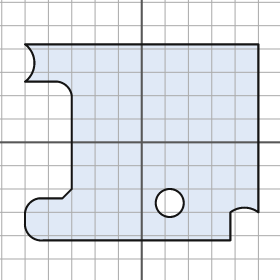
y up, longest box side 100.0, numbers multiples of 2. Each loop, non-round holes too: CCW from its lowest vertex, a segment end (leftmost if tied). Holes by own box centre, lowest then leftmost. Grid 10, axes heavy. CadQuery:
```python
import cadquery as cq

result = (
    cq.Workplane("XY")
    .moveTo(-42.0, -42.0)
    .lineTo(38.0, -42.0)
    .lineTo(38.0, -30.0)
    .threePointArc((44.0, -28.0), (50.0, -30.0))
    .lineTo(50.0, 42.0)
    .lineTo(-50.0, 42.0)
    .threePointArc((-46.0, 34.0), (-50.0, 26.0))
    .lineTo(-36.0, 26.0)
    .threePointArc((-32.0, 24.0), (-30.0, 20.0))
    .lineTo(-30.0, -20.0)
    .lineTo(-34.0, -24.0)
    .lineTo(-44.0, -24.0)
    .threePointArc((-48.0, -26.0), (-50.0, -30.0))
    .lineTo(-50.0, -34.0)
    .threePointArc((-48.0, -40.0), (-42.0, -42.0))
    .close()
    .moveTo(12.0, -26.0)
    .circle(6.0)
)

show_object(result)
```